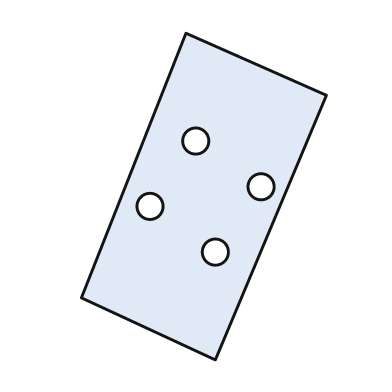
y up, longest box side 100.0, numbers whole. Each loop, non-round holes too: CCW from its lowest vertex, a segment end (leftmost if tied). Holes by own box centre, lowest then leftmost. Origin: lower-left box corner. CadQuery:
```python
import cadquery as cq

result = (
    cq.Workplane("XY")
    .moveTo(41.0, 0.0)
    .lineTo(75.0, 81.0)
    .lineTo(32.0, 100.0)
    .lineTo(0.0, 19.0)
    .close()
    .moveTo(41.0, 33.0)
    .circle(4.0)
    .moveTo(21.0, 47.0)
    .circle(4.0)
    .moveTo(55.0, 53.0)
    .circle(4.0)
    .moveTo(35.0, 67.0)
    .circle(4.0)
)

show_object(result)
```